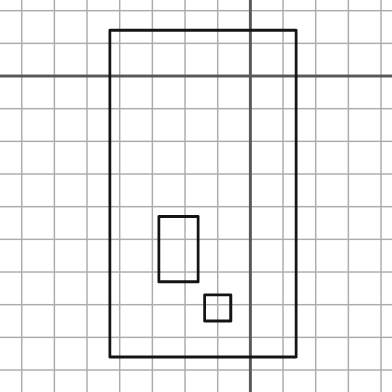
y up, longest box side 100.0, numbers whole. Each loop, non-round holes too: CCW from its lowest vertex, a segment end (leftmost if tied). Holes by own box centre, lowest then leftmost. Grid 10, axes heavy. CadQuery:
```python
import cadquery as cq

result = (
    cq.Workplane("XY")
    .moveTo(-43.0, -86.0)
    .lineTo(14.0, -86.0)
    .lineTo(14.0, 14.0)
    .lineTo(-43.0, 14.0)
    .close()
    .moveTo(-14.0, -75.0)
    .lineTo(-6.0, -75.0)
    .lineTo(-6.0, -67.0)
    .lineTo(-14.0, -67.0)
    .close()
    .moveTo(-28.0, -63.0)
    .lineTo(-16.0, -63.0)
    .lineTo(-16.0, -43.0)
    .lineTo(-28.0, -43.0)
    .close()
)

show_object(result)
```